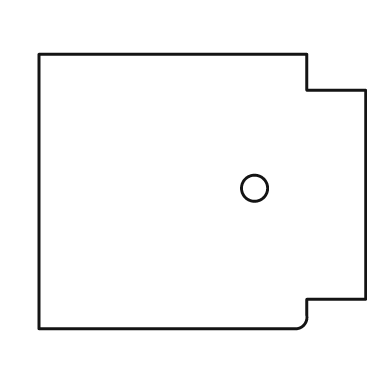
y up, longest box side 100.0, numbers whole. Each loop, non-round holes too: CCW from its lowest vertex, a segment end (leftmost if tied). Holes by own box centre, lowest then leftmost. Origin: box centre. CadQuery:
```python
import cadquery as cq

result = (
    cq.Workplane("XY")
    .moveTo(-50.0, -42.0)
    .lineTo(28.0, -42.0)
    .threePointArc((31.0, -41.0), (32.0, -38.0))
    .lineTo(32.0, -33.0)
    .lineTo(50.0, -33.0)
    .lineTo(50.0, 31.0)
    .lineTo(32.0, 31.0)
    .lineTo(32.0, 42.0)
    .lineTo(-50.0, 42.0)
    .close()
    .moveTo(16.0, 1.0)
    .circle(4.0)
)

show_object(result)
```